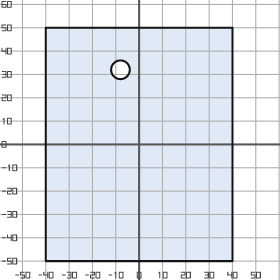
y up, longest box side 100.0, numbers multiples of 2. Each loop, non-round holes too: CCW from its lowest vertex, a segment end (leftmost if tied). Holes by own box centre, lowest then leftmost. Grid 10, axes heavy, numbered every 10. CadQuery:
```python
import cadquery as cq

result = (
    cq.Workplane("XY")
    .moveTo(-40.0, -50.0)
    .lineTo(40.0, -50.0)
    .lineTo(40.0, 50.0)
    .lineTo(-40.0, 50.0)
    .close()
    .moveTo(-8.0, 32.0)
    .circle(4.0)
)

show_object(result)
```